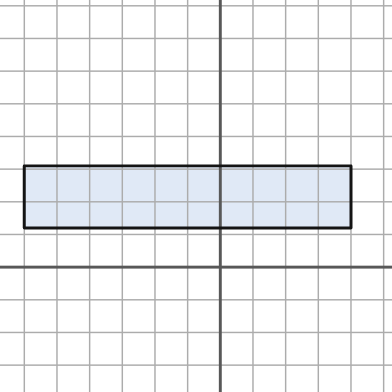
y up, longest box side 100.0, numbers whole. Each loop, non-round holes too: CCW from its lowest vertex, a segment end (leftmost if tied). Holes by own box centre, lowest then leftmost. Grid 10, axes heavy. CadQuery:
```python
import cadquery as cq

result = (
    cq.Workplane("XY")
    .moveTo(-60.0, 12.0)
    .lineTo(40.0, 12.0)
    .lineTo(40.0, 31.0)
    .lineTo(-60.0, 31.0)
    .close()
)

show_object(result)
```